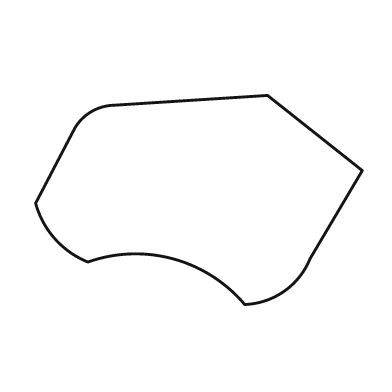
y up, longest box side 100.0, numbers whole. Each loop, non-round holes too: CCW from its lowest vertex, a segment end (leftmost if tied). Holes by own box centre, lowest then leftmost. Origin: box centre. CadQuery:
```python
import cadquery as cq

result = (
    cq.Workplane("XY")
    .moveTo(14.0, -32.0)
    .threePointArc((26.0, -28.0), (34.0, -18.0))
    .lineTo(50.0, 9.0)
    .lineTo(21.0, 32.0)
    .lineTo(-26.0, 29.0)
    .threePointArc((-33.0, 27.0), (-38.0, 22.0))
    .lineTo(-50.0, -1.0)
    .threePointArc((-44.0, -12.0), (-34.0, -19.0))
    .threePointArc((-8.0, -18.0), (14.0, -32.0))
    .close()
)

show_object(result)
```